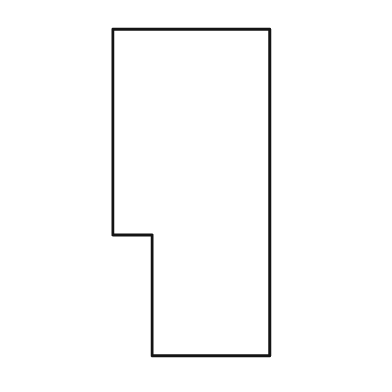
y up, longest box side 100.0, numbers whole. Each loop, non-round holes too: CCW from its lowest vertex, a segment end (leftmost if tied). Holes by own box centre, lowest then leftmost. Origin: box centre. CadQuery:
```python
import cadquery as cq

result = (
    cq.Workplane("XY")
    .moveTo(-12.0, -50.0)
    .lineTo(24.0, -50.0)
    .lineTo(24.0, 50.0)
    .lineTo(-24.0, 50.0)
    .lineTo(-24.0, -13.0)
    .lineTo(-12.0, -13.0)
    .close()
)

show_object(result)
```